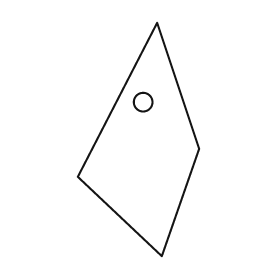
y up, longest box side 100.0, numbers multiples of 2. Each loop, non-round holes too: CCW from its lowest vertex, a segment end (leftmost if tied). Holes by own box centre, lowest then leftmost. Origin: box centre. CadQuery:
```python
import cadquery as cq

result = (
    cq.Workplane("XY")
    .moveTo(10.0, -50.0)
    .lineTo(26.0, -4.0)
    .lineTo(8.0, 50.0)
    .lineTo(-26.0, -16.0)
    .close()
    .moveTo(2.0, 16.0)
    .circle(4.0)
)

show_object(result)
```